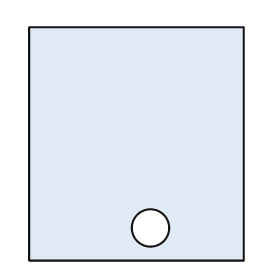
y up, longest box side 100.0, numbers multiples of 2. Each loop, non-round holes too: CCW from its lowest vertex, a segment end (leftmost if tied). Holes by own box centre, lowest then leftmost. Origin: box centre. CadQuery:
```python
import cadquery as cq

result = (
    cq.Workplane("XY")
    .moveTo(-46.0, -50.0)
    .lineTo(46.0, -50.0)
    .lineTo(46.0, 50.0)
    .lineTo(-46.0, 50.0)
    .close()
    .moveTo(6.0, -36.0)
    .circle(8.0)
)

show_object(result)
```